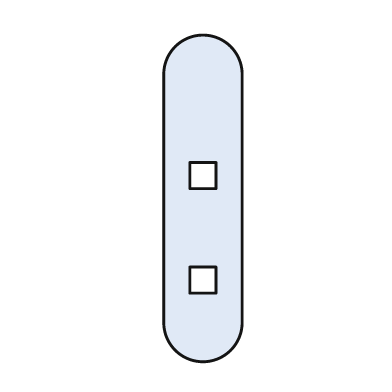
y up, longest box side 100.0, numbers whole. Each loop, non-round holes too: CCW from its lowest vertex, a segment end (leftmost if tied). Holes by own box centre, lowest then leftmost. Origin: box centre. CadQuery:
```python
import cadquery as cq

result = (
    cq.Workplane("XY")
    .moveTo(-12.0, -38.0)
    .threePointArc((0.0, -50.0), (12.0, -38.0))
    .lineTo(12.0, 38.0)
    .threePointArc((0.0, 50.0), (-12.0, 38.0))
    .close()
    .moveTo(-4.0, -29.0)
    .lineTo(4.0, -29.0)
    .lineTo(4.0, -21.0)
    .lineTo(-4.0, -21.0)
    .close()
    .moveTo(-4.0, 3.0)
    .lineTo(4.0, 3.0)
    .lineTo(4.0, 11.0)
    .lineTo(-4.0, 11.0)
    .close()
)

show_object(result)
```